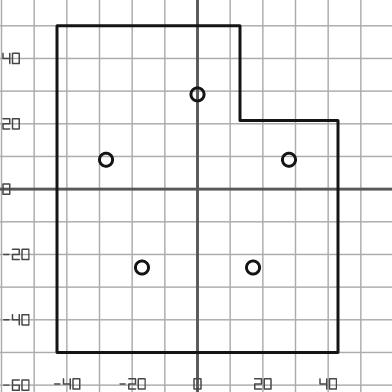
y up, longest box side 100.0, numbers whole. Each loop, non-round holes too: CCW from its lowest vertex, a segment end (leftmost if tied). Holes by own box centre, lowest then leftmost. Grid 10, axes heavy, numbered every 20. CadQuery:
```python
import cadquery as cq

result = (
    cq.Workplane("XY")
    .moveTo(-43.0, -50.0)
    .lineTo(43.0, -50.0)
    .lineTo(43.0, 21.0)
    .lineTo(13.0, 21.0)
    .lineTo(13.0, 50.0)
    .lineTo(-43.0, 50.0)
    .close()
    .moveTo(-17.0, -24.0)
    .circle(2.0)
    .moveTo(17.0, -24.0)
    .circle(2.0)
    .moveTo(-28.0, 9.0)
    .circle(2.0)
    .moveTo(28.0, 9.0)
    .circle(2.0)
    .moveTo(0.0, 29.0)
    .circle(2.0)
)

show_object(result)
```